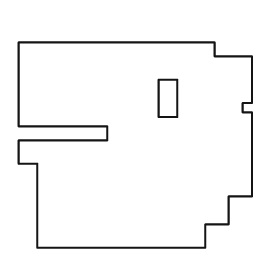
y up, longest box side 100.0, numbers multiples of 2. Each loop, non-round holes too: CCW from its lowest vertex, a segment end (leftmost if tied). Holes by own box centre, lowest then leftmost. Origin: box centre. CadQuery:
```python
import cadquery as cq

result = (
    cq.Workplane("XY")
    .moveTo(-42.0, -44.0)
    .lineTo(30.0, -44.0)
    .lineTo(30.0, -34.0)
    .lineTo(40.0, -34.0)
    .lineTo(40.0, -22.0)
    .lineTo(50.0, -22.0)
    .lineTo(50.0, 14.0)
    .lineTo(46.0, 14.0)
    .lineTo(46.0, 18.0)
    .lineTo(50.0, 18.0)
    .lineTo(50.0, 38.0)
    .lineTo(34.0, 38.0)
    .lineTo(34.0, 44.0)
    .lineTo(-50.0, 44.0)
    .lineTo(-50.0, 8.0)
    .lineTo(-12.0, 8.0)
    .lineTo(-12.0, 2.0)
    .lineTo(-50.0, 2.0)
    .lineTo(-50.0, -8.0)
    .lineTo(-42.0, -8.0)
    .close()
    .moveTo(10.0, 12.0)
    .lineTo(18.0, 12.0)
    .lineTo(18.0, 28.0)
    .lineTo(10.0, 28.0)
    .close()
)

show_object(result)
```